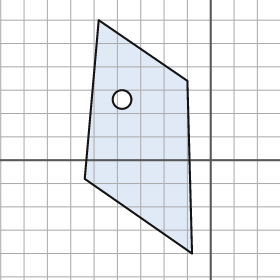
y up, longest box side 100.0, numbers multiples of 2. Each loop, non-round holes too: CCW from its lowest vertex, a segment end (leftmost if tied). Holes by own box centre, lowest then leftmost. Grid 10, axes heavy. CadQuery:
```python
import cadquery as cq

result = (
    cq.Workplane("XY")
    .moveTo(-8.0, -40.0)
    .lineTo(-10.0, 34.0)
    .lineTo(-48.0, 60.0)
    .lineTo(-54.0, -8.0)
    .close()
    .moveTo(-38.0, 26.0)
    .circle(4.0)
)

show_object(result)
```